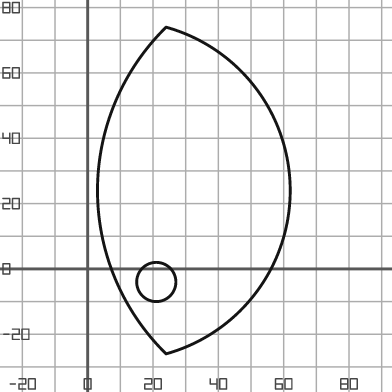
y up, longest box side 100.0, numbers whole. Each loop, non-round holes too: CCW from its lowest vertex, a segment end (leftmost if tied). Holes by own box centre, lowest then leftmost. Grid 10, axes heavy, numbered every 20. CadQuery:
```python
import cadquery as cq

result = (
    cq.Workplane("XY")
    .moveTo(24.0, -26.0)
    .threePointArc((62.0, 24.0), (24.0, 74.0))
    .threePointArc((3.0, 24.0), (24.0, -26.0))
    .close()
    .moveTo(21.0, -4.0)
    .circle(6.0)
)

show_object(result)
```